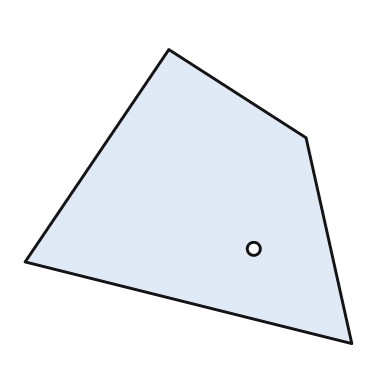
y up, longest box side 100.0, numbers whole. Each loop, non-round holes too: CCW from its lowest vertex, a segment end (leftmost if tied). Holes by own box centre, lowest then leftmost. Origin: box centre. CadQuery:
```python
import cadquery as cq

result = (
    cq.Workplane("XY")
    .moveTo(50.0, -45.0)
    .lineTo(36.0, 18.0)
    .lineTo(-6.0, 45.0)
    .lineTo(-50.0, -20.0)
    .close()
    .moveTo(20.0, -16.0)
    .circle(2.0)
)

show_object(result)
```